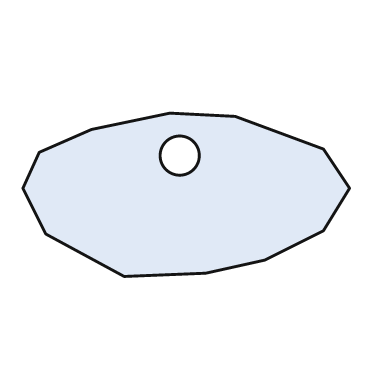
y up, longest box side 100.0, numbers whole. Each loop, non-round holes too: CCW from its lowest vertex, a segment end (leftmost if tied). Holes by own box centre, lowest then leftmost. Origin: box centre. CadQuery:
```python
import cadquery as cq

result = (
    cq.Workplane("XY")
    .moveTo(-19.0, -25.0)
    .lineTo(6.0, -24.0)
    .lineTo(24.0, -20.0)
    .lineTo(42.0, -11.0)
    .lineTo(50.0, 2.0)
    .lineTo(42.0, 14.0)
    .lineTo(15.0, 24.0)
    .lineTo(-5.0, 25.0)
    .lineTo(-29.0, 20.0)
    .lineTo(-45.0, 13.0)
    .lineTo(-50.0, 2.0)
    .lineTo(-43.0, -12.0)
    .close()
    .moveTo(-2.0, 12.0)
    .circle(6.0)
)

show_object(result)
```